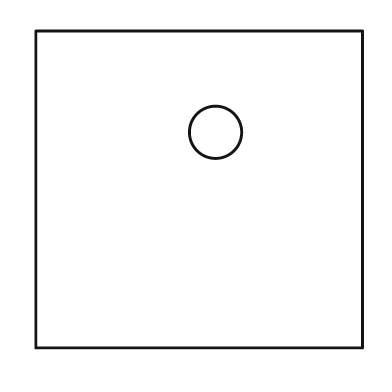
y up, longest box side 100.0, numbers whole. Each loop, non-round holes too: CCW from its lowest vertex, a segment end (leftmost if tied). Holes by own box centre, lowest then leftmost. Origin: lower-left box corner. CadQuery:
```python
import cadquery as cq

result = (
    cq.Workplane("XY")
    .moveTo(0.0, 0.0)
    .lineTo(100.0, 0.0)
    .lineTo(100.0, 97.0)
    .lineTo(0.0, 97.0)
    .close()
    .moveTo(55.0, 66.0)
    .circle(8.0)
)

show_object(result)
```